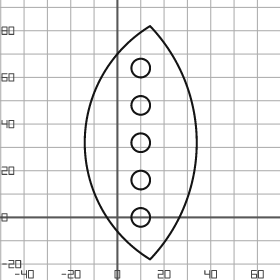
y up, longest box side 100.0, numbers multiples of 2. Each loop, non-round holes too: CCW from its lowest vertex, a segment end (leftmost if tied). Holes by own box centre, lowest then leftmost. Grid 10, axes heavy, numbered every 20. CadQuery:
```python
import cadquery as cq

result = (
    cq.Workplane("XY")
    .moveTo(14.0, -18.0)
    .threePointArc((34.0, 32.0), (14.0, 82.0))
    .threePointArc((-14.0, 32.0), (14.0, -18.0))
    .close()
    .moveTo(10.0, 0.0)
    .circle(4.0)
    .moveTo(10.0, 16.0)
    .circle(4.0)
    .moveTo(10.0, 32.0)
    .circle(4.0)
    .moveTo(10.0, 48.0)
    .circle(4.0)
    .moveTo(10.0, 64.0)
    .circle(4.0)
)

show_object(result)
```